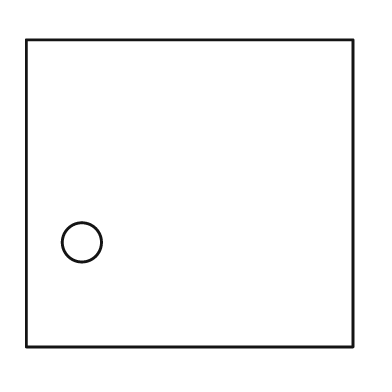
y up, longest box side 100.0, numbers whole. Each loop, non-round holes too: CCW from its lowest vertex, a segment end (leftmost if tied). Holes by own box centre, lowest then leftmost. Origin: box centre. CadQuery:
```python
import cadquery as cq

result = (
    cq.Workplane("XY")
    .moveTo(-50.0, -47.0)
    .lineTo(50.0, -47.0)
    .lineTo(50.0, 47.0)
    .lineTo(-50.0, 47.0)
    .close()
    .moveTo(-33.0, -15.0)
    .circle(6.0)
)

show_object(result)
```